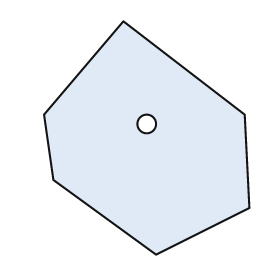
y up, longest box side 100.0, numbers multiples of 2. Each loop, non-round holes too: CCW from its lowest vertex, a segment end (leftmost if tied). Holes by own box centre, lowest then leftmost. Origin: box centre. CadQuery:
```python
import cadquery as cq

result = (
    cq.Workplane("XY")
    .moveTo(4.0, -50.0)
    .lineTo(44.0, -30.0)
    .lineTo(42.0, 10.0)
    .lineTo(-10.0, 50.0)
    .lineTo(-44.0, 10.0)
    .lineTo(-40.0, -18.0)
    .close()
    .moveTo(0.0, 6.0)
    .circle(4.0)
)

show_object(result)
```